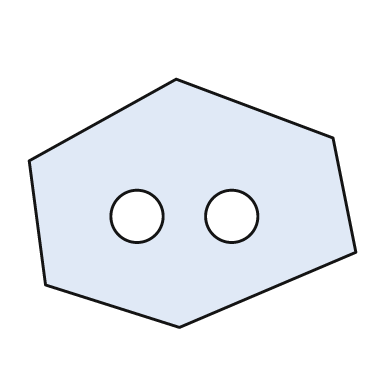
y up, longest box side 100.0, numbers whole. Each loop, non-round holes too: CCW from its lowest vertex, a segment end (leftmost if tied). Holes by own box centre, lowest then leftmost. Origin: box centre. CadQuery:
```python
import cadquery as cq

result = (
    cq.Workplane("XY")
    .moveTo(-4.0, -38.0)
    .lineTo(50.0, -15.0)
    .lineTo(43.0, 20.0)
    .lineTo(-5.0, 38.0)
    .lineTo(-50.0, 13.0)
    .lineTo(-45.0, -25.0)
    .close()
    .moveTo(-17.0, -4.0)
    .circle(8.0)
    .moveTo(12.0, -4.0)
    .circle(8.0)
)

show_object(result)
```